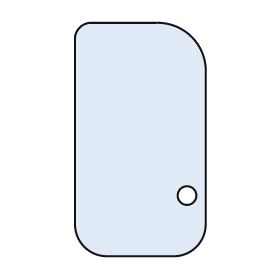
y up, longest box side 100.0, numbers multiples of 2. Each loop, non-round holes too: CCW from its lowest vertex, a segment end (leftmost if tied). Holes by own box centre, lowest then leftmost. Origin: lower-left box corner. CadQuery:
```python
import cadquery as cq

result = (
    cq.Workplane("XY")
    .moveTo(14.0, 0.0)
    .lineTo(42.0, 0.0)
    .threePointArc((52.0, 4.0), (56.0, 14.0))
    .lineTo(56.0, 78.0)
    .threePointArc((50.0, 94.0), (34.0, 100.0))
    .lineTo(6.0, 100.0)
    .threePointArc((2.0, 98.0), (0.0, 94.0))
    .lineTo(0.0, 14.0)
    .threePointArc((4.0, 4.0), (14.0, 0.0))
    .close()
    .moveTo(48.0, 26.0)
    .circle(4.0)
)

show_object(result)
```